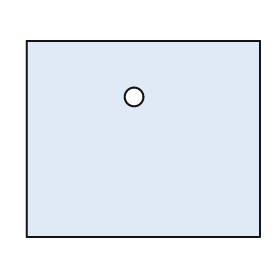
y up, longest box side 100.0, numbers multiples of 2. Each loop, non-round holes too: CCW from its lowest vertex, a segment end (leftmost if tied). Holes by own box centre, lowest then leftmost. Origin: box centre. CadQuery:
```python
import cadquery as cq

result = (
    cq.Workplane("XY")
    .moveTo(-50.0, -42.0)
    .lineTo(50.0, -42.0)
    .lineTo(50.0, 42.0)
    .lineTo(-50.0, 42.0)
    .close()
    .moveTo(-4.0, 18.0)
    .circle(4.0)
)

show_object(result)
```